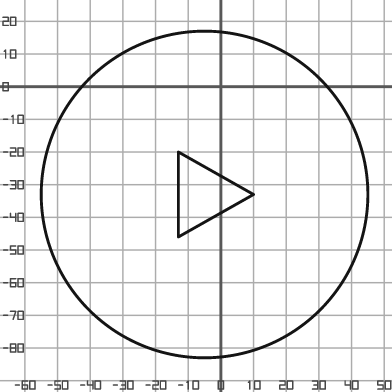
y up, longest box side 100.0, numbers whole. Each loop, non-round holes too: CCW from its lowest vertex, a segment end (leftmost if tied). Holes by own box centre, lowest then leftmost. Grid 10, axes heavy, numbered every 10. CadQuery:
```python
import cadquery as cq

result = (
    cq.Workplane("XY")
    .moveTo(-5.0, -33.0)
    .circle(50.0)
    .moveTo(-13.0, -46.0)
    .lineTo(10.0, -33.0)
    .lineTo(-13.0, -20.0)
    .close()
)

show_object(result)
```